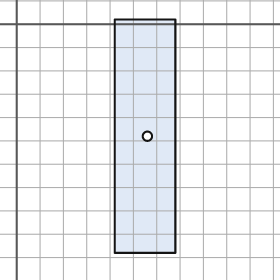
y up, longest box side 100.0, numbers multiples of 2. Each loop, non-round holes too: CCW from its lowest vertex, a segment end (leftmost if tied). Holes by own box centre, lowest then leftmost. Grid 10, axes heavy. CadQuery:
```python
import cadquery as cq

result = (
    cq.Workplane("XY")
    .moveTo(42.0, -98.0)
    .lineTo(68.0, -98.0)
    .lineTo(68.0, 2.0)
    .lineTo(42.0, 2.0)
    .close()
    .moveTo(56.0, -48.0)
    .circle(2.0)
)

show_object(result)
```